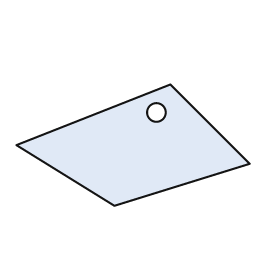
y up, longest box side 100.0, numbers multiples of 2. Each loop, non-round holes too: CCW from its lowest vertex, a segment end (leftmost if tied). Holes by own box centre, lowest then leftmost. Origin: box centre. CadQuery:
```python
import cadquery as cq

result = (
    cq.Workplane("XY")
    .moveTo(-8.0, -26.0)
    .lineTo(50.0, -8.0)
    .lineTo(16.0, 26.0)
    .lineTo(-50.0, 0.0)
    .close()
    .moveTo(10.0, 14.0)
    .circle(4.0)
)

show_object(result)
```